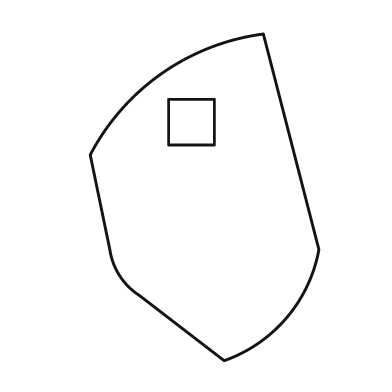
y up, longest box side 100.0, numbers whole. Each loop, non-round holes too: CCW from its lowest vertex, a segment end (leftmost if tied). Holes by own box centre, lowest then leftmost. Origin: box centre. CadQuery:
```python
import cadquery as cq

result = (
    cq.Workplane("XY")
    .moveTo(6.0, -50.0)
    .threePointArc((25.0, -37.0), (35.0, -16.0))
    .lineTo(18.0, 50.0)
    .threePointArc((-13.0, 38.0), (-35.0, 13.0))
    .lineTo(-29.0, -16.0)
    .threePointArc((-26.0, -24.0), (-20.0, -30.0))
    .close()
    .moveTo(-11.0, 16.0)
    .lineTo(3.0, 16.0)
    .lineTo(3.0, 30.0)
    .lineTo(-11.0, 30.0)
    .close()
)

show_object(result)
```